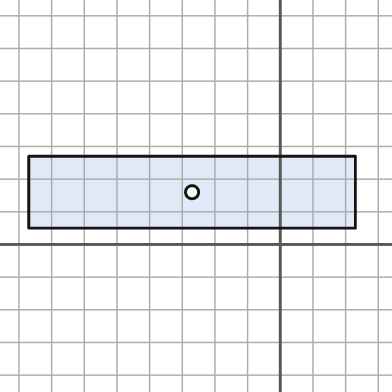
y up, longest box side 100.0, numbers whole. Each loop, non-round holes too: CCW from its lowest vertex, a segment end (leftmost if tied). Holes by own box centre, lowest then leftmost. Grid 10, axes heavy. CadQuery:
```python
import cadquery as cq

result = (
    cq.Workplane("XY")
    .moveTo(-77.0, 5.0)
    .lineTo(23.0, 5.0)
    .lineTo(23.0, 27.0)
    .lineTo(-77.0, 27.0)
    .close()
    .moveTo(-27.0, 16.0)
    .circle(2.0)
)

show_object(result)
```